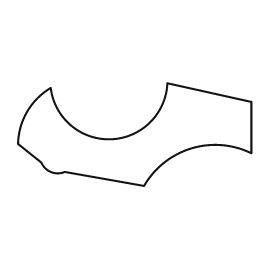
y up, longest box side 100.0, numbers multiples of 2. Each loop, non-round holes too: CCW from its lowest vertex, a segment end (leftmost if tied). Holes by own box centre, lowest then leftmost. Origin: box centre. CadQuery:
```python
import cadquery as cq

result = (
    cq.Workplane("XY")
    .moveTo(4.0, -22.0)
    .threePointArc((24.0, -6.0), (50.0, -8.0))
    .lineTo(50.0, 14.0)
    .lineTo(14.0, 22.0)
    .threePointArc((-10.0, -2.0), (-36.0, 20.0))
    .threePointArc((-46.0, 10.0), (-50.0, -4.0))
    .lineTo(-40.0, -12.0)
    .threePointArc((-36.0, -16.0), (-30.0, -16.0))
    .close()
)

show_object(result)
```